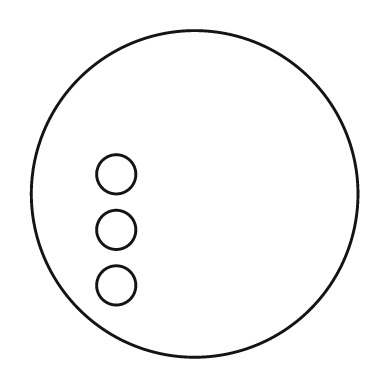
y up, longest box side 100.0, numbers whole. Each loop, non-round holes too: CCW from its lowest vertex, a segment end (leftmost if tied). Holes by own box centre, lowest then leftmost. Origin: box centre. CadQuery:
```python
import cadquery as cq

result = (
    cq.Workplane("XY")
    .moveTo(0.0, 0.0)
    .circle(50.0)
    .moveTo(-24.0, -28.0)
    .circle(6.0)
    .moveTo(-24.0, -11.0)
    .circle(6.0)
    .moveTo(-24.0, 6.0)
    .circle(6.0)
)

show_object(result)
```